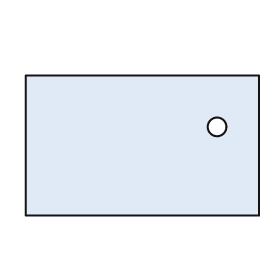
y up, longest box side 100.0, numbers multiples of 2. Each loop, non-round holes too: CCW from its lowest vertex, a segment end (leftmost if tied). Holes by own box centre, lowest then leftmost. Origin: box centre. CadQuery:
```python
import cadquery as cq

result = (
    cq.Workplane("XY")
    .moveTo(-50.0, -30.0)
    .lineTo(50.0, -30.0)
    .lineTo(50.0, 30.0)
    .lineTo(-50.0, 30.0)
    .close()
    .moveTo(32.0, 8.0)
    .circle(4.0)
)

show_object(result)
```